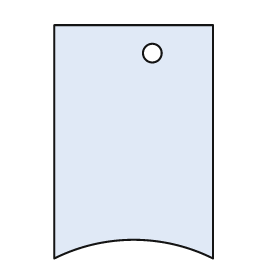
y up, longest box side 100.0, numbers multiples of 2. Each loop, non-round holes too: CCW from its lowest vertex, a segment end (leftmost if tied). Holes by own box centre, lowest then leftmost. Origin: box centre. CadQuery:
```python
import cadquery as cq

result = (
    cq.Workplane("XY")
    .moveTo(-34.0, -50.0)
    .threePointArc((0.0, -42.0), (34.0, -50.0))
    .lineTo(34.0, 50.0)
    .lineTo(-34.0, 50.0)
    .close()
    .moveTo(8.0, 38.0)
    .circle(4.0)
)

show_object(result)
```